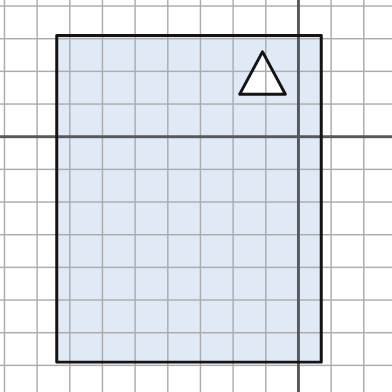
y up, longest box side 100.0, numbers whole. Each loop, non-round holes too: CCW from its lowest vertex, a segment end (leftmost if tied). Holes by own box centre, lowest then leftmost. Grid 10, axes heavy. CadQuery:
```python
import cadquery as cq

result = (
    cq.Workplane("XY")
    .moveTo(-74.0, -69.0)
    .lineTo(7.0, -69.0)
    .lineTo(7.0, 31.0)
    .lineTo(-74.0, 31.0)
    .close()
    .moveTo(-18.0, 13.0)
    .lineTo(-4.0, 13.0)
    .lineTo(-11.0, 26.0)
    .close()
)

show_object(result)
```